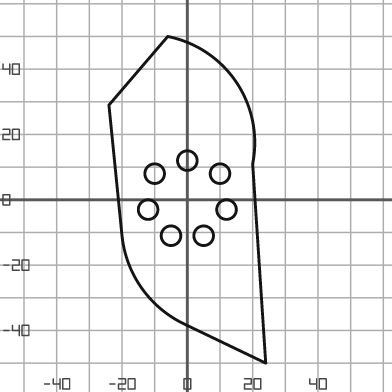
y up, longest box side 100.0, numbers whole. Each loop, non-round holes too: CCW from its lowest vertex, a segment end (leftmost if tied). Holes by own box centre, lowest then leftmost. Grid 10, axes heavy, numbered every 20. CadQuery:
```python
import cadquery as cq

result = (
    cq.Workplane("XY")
    .moveTo(24.0, -50.0)
    .lineTo(20.0, 11.0)
    .threePointArc((15.0, 36.0), (-6.0, 50.0))
    .lineTo(-24.0, 29.0)
    .lineTo(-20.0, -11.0)
    .threePointArc((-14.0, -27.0), (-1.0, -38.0))
    .close()
    .moveTo(-5.0, -11.0)
    .circle(3.0)
    .moveTo(5.0, -11.0)
    .circle(3.0)
    .moveTo(-12.0, -3.0)
    .circle(3.0)
    .moveTo(12.0, -3.0)
    .circle(3.0)
    .moveTo(-10.0, 8.0)
    .circle(3.0)
    .moveTo(10.0, 8.0)
    .circle(3.0)
    .moveTo(0.0, 12.0)
    .circle(3.0)
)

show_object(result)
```